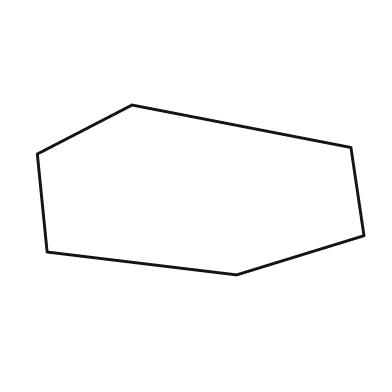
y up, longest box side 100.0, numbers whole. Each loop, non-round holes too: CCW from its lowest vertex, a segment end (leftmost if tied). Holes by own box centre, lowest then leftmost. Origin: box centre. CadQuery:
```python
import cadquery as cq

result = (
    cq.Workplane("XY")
    .moveTo(11.0, -26.0)
    .lineTo(50.0, -14.0)
    .lineTo(46.0, 13.0)
    .lineTo(-21.0, 26.0)
    .lineTo(-50.0, 11.0)
    .lineTo(-47.0, -19.0)
    .close()
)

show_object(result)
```